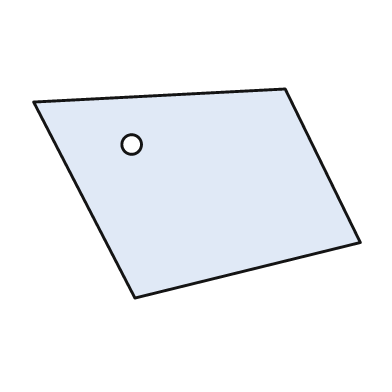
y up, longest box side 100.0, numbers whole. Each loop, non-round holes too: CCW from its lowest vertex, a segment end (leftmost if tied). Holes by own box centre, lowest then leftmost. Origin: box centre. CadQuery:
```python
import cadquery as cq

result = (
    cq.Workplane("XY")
    .moveTo(-19.0, -32.0)
    .lineTo(50.0, -15.0)
    .lineTo(27.0, 32.0)
    .lineTo(-50.0, 28.0)
    .close()
    .moveTo(-20.0, 15.0)
    .circle(3.0)
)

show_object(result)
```